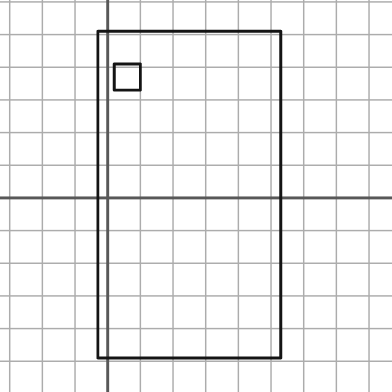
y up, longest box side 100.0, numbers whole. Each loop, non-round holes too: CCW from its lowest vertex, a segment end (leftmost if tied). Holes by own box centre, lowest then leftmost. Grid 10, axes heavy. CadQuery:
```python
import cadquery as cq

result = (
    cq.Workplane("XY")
    .moveTo(-3.0, -49.0)
    .lineTo(53.0, -49.0)
    .lineTo(53.0, 51.0)
    .lineTo(-3.0, 51.0)
    .close()
    .moveTo(2.0, 33.0)
    .lineTo(10.0, 33.0)
    .lineTo(10.0, 41.0)
    .lineTo(2.0, 41.0)
    .close()
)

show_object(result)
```